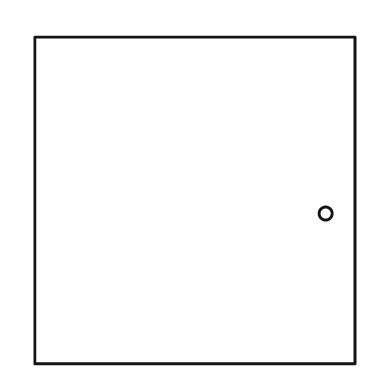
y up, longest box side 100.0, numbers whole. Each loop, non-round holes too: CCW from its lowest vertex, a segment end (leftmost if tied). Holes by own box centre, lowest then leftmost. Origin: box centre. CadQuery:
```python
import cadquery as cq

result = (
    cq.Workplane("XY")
    .moveTo(-49.0, -50.0)
    .lineTo(49.0, -50.0)
    .lineTo(49.0, 50.0)
    .lineTo(-49.0, 50.0)
    .close()
    .moveTo(40.0, -4.0)
    .circle(2.0)
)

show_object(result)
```